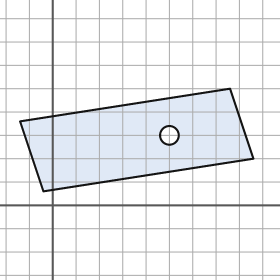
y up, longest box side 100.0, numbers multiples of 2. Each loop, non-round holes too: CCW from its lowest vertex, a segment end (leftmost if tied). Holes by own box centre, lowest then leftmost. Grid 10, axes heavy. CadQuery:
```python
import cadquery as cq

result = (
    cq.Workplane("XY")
    .moveTo(-4.0, 6.0)
    .lineTo(86.0, 20.0)
    .lineTo(76.0, 50.0)
    .lineTo(-14.0, 36.0)
    .close()
    .moveTo(50.0, 30.0)
    .circle(4.0)
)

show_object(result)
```